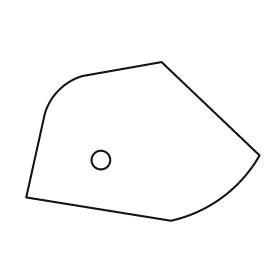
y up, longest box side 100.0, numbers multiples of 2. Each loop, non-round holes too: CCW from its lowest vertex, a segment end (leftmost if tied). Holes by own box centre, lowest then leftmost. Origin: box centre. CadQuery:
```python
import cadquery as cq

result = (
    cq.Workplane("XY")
    .moveTo(12.0, -34.0)
    .threePointArc((34.0, -24.0), (50.0, -6.0))
    .lineTo(8.0, 34.0)
    .lineTo(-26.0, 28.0)
    .threePointArc((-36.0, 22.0), (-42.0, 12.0))
    .lineTo(-50.0, -24.0)
    .close()
    .moveTo(-18.0, -8.0)
    .circle(4.0)
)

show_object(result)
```